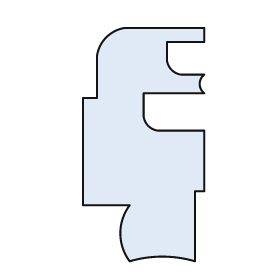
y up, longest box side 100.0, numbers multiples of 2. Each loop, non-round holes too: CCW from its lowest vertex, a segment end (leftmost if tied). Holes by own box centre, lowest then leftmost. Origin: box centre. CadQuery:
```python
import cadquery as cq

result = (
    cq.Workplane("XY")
    .moveTo(-6.0, -50.0)
    .threePointArc((8.0, -48.0), (22.0, -50.0))
    .lineTo(22.0, -20.0)
    .lineTo(26.0, -20.0)
    .lineTo(26.0, 6.0)
    .lineTo(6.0, 6.0)
    .threePointArc((2.0, 8.0), (0.0, 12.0))
    .lineTo(0.0, 22.0)
    .lineTo(26.0, 22.0)
    .threePointArc((24.0, 26.0), (26.0, 30.0))
    .lineTo(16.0, 30.0)
    .threePointArc((12.0, 32.0), (10.0, 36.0))
    .lineTo(10.0, 44.0)
    .lineTo(26.0, 44.0)
    .lineTo(26.0, 50.0)
    .lineTo(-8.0, 50.0)
    .threePointArc((-16.0, 46.0), (-20.0, 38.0))
    .lineTo(-20.0, 20.0)
    .lineTo(-26.0, 20.0)
    .lineTo(-26.0, -26.0)
    .lineTo(-6.0, -26.0)
    .threePointArc((-10.0, -38.0), (-6.0, -50.0))
    .close()
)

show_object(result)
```